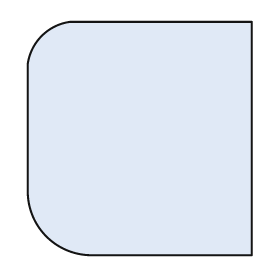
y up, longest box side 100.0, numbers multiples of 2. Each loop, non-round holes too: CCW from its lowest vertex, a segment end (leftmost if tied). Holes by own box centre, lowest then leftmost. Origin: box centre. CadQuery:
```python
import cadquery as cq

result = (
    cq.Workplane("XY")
    .moveTo(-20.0, -50.0)
    .lineTo(48.0, -50.0)
    .lineTo(48.0, 50.0)
    .lineTo(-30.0, 50.0)
    .threePointArc((-42.0, 44.0), (-48.0, 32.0))
    .lineTo(-48.0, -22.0)
    .threePointArc((-40.0, -42.0), (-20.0, -50.0))
    .close()
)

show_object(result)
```